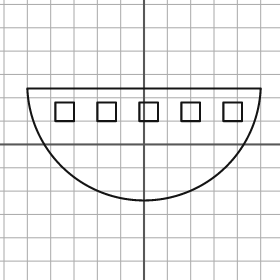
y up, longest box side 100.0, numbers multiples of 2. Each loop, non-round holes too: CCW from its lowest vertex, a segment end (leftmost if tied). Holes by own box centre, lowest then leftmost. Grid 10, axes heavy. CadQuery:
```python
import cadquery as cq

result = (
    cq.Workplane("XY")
    .moveTo(-50.0, 24.0)
    .threePointArc((0.0, -24.0), (50.0, 24.0))
    .close()
    .moveTo(-38.0, 10.0)
    .lineTo(-30.0, 10.0)
    .lineTo(-30.0, 18.0)
    .lineTo(-38.0, 18.0)
    .close()
    .moveTo(-20.0, 10.0)
    .lineTo(-12.0, 10.0)
    .lineTo(-12.0, 18.0)
    .lineTo(-20.0, 18.0)
    .close()
    .moveTo(-2.0, 10.0)
    .lineTo(6.0, 10.0)
    .lineTo(6.0, 18.0)
    .lineTo(-2.0, 18.0)
    .close()
    .moveTo(16.0, 10.0)
    .lineTo(24.0, 10.0)
    .lineTo(24.0, 18.0)
    .lineTo(16.0, 18.0)
    .close()
    .moveTo(34.0, 10.0)
    .lineTo(42.0, 10.0)
    .lineTo(42.0, 18.0)
    .lineTo(34.0, 18.0)
    .close()
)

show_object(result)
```